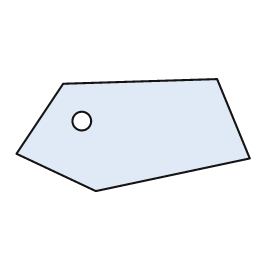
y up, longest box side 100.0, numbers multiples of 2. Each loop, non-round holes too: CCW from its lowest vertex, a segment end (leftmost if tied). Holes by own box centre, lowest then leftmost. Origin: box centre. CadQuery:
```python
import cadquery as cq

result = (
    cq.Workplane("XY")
    .moveTo(-16.0, -24.0)
    .lineTo(50.0, -10.0)
    .lineTo(36.0, 24.0)
    .lineTo(-30.0, 22.0)
    .lineTo(-50.0, -8.0)
    .close()
    .moveTo(-22.0, 6.0)
    .circle(4.0)
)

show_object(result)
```